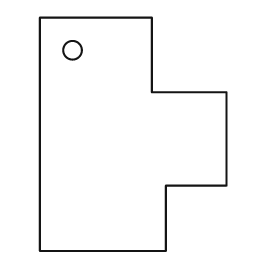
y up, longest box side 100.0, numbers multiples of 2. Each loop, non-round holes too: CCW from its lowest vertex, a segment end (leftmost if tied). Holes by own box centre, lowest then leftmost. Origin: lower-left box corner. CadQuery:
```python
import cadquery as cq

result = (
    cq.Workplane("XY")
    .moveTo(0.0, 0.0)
    .lineTo(54.0, 0.0)
    .lineTo(54.0, 28.0)
    .lineTo(80.0, 28.0)
    .lineTo(80.0, 68.0)
    .lineTo(48.0, 68.0)
    .lineTo(48.0, 100.0)
    .lineTo(0.0, 100.0)
    .close()
    .moveTo(14.0, 86.0)
    .circle(4.0)
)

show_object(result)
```